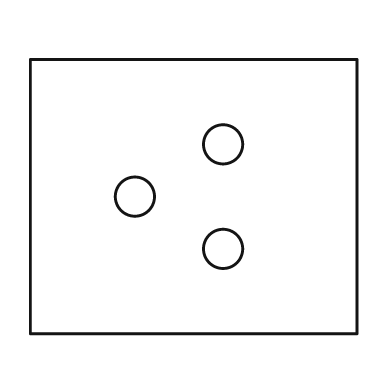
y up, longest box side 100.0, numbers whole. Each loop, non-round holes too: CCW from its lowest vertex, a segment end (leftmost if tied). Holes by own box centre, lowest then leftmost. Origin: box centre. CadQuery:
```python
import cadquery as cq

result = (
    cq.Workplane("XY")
    .moveTo(-50.0, -42.0)
    .lineTo(50.0, -42.0)
    .lineTo(50.0, 42.0)
    .lineTo(-50.0, 42.0)
    .close()
    .moveTo(9.0, -16.0)
    .circle(6.0)
    .moveTo(-18.0, 0.0)
    .circle(6.0)
    .moveTo(9.0, 16.0)
    .circle(6.0)
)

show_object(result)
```